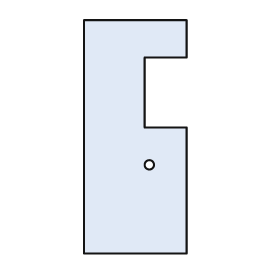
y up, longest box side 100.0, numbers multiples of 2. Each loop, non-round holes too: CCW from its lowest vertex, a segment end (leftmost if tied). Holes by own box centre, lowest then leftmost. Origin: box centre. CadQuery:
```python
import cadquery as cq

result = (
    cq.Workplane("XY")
    .moveTo(-22.0, -50.0)
    .lineTo(22.0, -50.0)
    .lineTo(22.0, 4.0)
    .lineTo(4.0, 4.0)
    .lineTo(4.0, 34.0)
    .lineTo(22.0, 34.0)
    .lineTo(22.0, 50.0)
    .lineTo(-22.0, 50.0)
    .close()
    .moveTo(6.0, -12.0)
    .circle(2.0)
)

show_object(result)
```